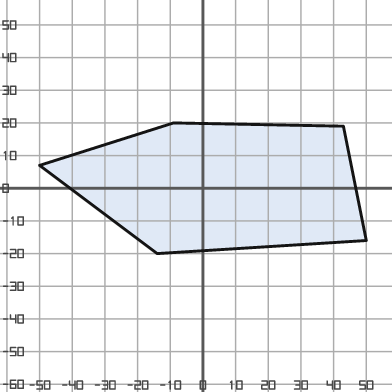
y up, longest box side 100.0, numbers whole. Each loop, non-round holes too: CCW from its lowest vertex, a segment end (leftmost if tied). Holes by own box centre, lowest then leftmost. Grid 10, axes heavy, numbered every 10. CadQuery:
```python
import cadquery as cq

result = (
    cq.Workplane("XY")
    .moveTo(-14.0, -20.0)
    .lineTo(50.0, -16.0)
    .lineTo(43.0, 19.0)
    .lineTo(-9.0, 20.0)
    .lineTo(-50.0, 7.0)
    .close()
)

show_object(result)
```